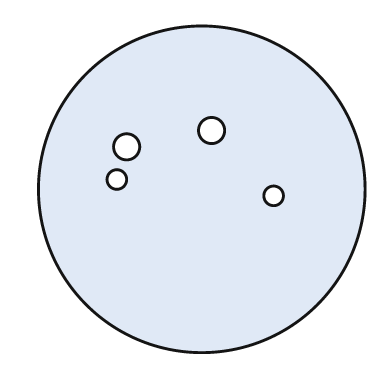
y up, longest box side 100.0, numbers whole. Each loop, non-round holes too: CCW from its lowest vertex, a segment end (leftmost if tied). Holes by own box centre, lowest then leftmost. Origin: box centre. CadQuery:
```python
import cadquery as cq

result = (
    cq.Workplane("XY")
    .moveTo(0.0, 0.0)
    .circle(50.0)
    .moveTo(22.0, -2.0)
    .circle(3.0)
    .moveTo(-26.0, 3.0)
    .circle(3.0)
    .moveTo(-23.0, 13.0)
    .circle(4.0)
    .moveTo(3.0, 18.0)
    .circle(4.0)
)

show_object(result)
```